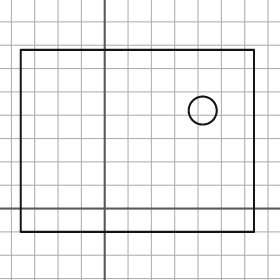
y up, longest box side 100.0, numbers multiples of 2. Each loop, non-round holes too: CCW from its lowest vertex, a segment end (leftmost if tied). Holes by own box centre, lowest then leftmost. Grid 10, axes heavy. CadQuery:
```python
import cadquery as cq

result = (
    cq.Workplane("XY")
    .moveTo(-36.0, -10.0)
    .lineTo(64.0, -10.0)
    .lineTo(64.0, 68.0)
    .lineTo(-36.0, 68.0)
    .close()
    .moveTo(42.0, 42.0)
    .circle(6.0)
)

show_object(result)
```